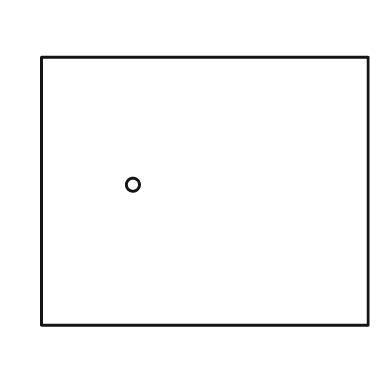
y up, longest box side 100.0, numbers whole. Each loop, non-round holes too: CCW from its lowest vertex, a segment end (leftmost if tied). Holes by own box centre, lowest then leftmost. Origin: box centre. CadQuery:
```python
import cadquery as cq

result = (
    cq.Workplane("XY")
    .moveTo(-50.0, -41.0)
    .lineTo(50.0, -41.0)
    .lineTo(50.0, 41.0)
    .lineTo(-50.0, 41.0)
    .close()
    .moveTo(-22.0, 2.0)
    .circle(2.0)
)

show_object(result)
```